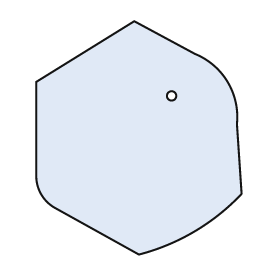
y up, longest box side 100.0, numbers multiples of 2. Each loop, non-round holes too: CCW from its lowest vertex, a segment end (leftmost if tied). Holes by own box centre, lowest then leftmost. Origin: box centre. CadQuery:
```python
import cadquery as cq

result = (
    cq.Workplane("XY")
    .moveTo(0.0, -50.0)
    .threePointArc((24.0, -40.0), (44.0, -24.0))
    .lineTo(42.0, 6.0)
    .threePointArc((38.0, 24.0), (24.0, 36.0))
    .lineTo(-2.0, 50.0)
    .lineTo(-44.0, 24.0)
    .lineTo(-44.0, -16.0)
    .threePointArc((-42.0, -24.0), (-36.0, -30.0))
    .close()
    .moveTo(14.0, 18.0)
    .circle(2.0)
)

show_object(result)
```